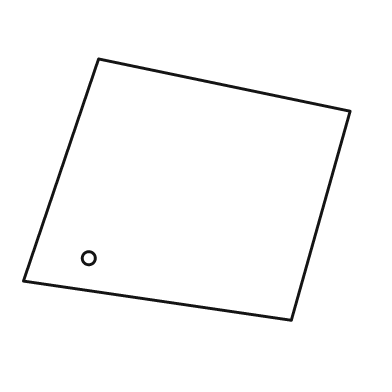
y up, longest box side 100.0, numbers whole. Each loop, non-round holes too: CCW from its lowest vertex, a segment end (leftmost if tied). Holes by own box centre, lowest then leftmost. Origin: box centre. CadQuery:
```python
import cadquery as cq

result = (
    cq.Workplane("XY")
    .moveTo(32.0, -40.0)
    .lineTo(50.0, 24.0)
    .lineTo(-27.0, 40.0)
    .lineTo(-50.0, -28.0)
    .close()
    .moveTo(-30.0, -21.0)
    .circle(2.0)
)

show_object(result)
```